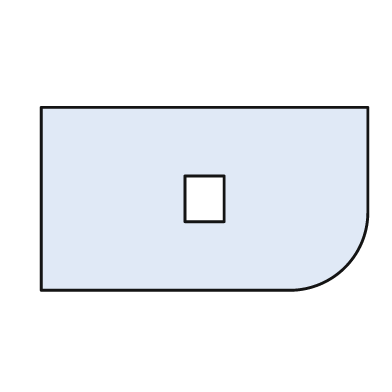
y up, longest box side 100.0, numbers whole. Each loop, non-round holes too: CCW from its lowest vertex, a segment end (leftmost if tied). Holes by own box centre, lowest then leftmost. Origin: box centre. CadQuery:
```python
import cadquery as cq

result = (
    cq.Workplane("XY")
    .moveTo(-50.0, -28.0)
    .lineTo(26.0, -28.0)
    .threePointArc((43.0, -21.0), (50.0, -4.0))
    .lineTo(50.0, 28.0)
    .lineTo(-50.0, 28.0)
    .close()
    .moveTo(-6.0, -7.0)
    .lineTo(6.0, -7.0)
    .lineTo(6.0, 7.0)
    .lineTo(-6.0, 7.0)
    .close()
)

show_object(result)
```